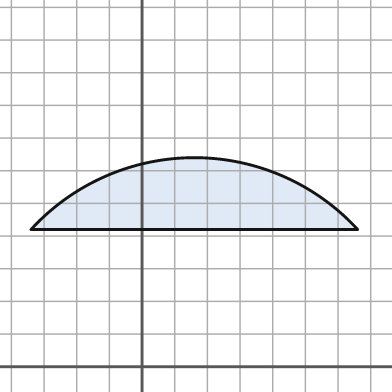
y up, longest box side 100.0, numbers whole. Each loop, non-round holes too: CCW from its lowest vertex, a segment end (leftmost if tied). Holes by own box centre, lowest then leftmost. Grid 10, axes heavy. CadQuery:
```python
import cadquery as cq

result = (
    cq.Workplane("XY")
    .moveTo(-34.0, 42.0)
    .lineTo(66.0, 42.0)
    .threePointArc((16.0, 64.0), (-34.0, 42.0))
    .close()
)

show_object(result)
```